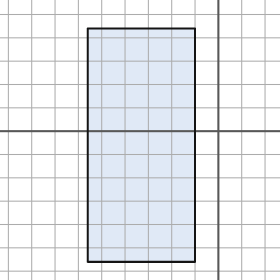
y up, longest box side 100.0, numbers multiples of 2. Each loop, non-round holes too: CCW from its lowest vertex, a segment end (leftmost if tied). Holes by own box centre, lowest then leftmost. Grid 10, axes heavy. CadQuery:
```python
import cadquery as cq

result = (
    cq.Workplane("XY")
    .moveTo(-56.0, -56.0)
    .lineTo(-10.0, -56.0)
    .lineTo(-10.0, 44.0)
    .lineTo(-56.0, 44.0)
    .close()
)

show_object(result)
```